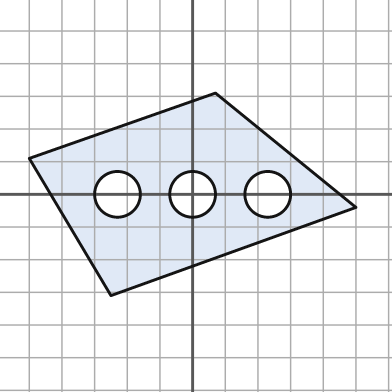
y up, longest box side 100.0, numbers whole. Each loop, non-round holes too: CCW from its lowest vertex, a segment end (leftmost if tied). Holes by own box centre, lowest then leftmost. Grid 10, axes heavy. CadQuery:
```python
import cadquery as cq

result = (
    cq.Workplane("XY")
    .moveTo(-25.0, -31.0)
    .lineTo(50.0, -4.0)
    .lineTo(7.0, 31.0)
    .lineTo(-50.0, 11.0)
    .close()
    .moveTo(-23.0, 0.0)
    .circle(7.0)
    .moveTo(0.0, 0.0)
    .circle(7.0)
    .moveTo(23.0, 0.0)
    .circle(7.0)
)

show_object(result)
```